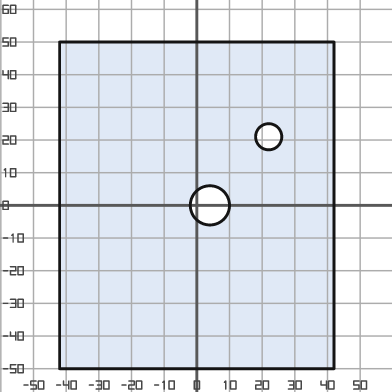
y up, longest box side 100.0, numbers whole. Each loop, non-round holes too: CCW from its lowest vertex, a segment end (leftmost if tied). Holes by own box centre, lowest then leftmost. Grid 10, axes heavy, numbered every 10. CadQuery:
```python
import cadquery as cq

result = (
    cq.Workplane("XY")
    .moveTo(-42.0, -50.0)
    .lineTo(42.0, -50.0)
    .lineTo(42.0, 50.0)
    .lineTo(-42.0, 50.0)
    .close()
    .moveTo(4.0, 0.0)
    .circle(6.0)
    .moveTo(22.0, 21.0)
    .circle(4.0)
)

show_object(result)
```